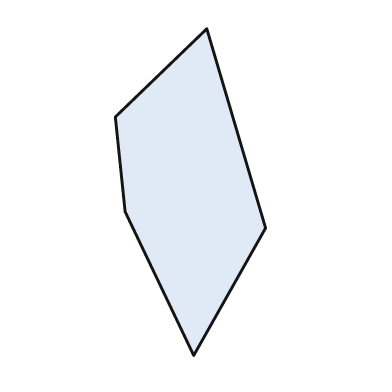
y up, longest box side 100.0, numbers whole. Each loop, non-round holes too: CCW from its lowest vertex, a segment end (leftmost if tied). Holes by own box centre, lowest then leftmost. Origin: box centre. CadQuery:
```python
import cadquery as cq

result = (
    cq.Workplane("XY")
    .moveTo(1.0, -50.0)
    .lineTo(23.0, -11.0)
    .lineTo(5.0, 50.0)
    .lineTo(-23.0, 23.0)
    .lineTo(-20.0, -6.0)
    .close()
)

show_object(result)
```